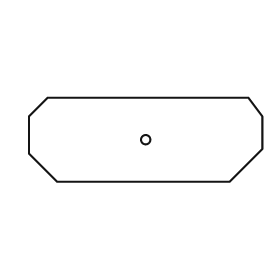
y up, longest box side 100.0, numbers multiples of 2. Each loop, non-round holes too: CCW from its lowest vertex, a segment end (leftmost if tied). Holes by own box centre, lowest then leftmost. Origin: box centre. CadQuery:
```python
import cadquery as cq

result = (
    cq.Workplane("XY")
    .moveTo(-38.0, -18.0)
    .lineTo(36.0, -18.0)
    .lineTo(50.0, -4.0)
    .lineTo(50.0, 10.0)
    .lineTo(44.0, 18.0)
    .lineTo(-42.0, 18.0)
    .lineTo(-50.0, 10.0)
    .lineTo(-50.0, -6.0)
    .close()
    .moveTo(0.0, 0.0)
    .circle(2.0)
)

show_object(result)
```